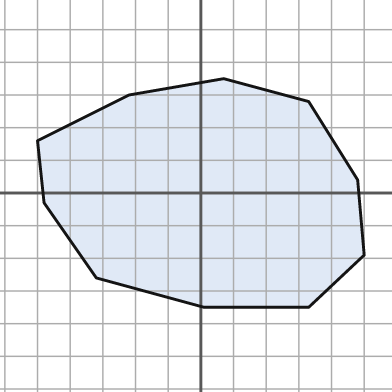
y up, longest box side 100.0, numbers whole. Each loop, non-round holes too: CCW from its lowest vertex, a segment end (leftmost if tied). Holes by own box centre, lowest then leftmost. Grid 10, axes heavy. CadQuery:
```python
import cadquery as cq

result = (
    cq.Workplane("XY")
    .moveTo(1.0, -35.0)
    .lineTo(33.0, -35.0)
    .lineTo(50.0, -19.0)
    .lineTo(48.0, 4.0)
    .lineTo(33.0, 28.0)
    .lineTo(7.0, 35.0)
    .lineTo(-22.0, 30.0)
    .lineTo(-50.0, 16.0)
    .lineTo(-48.0, -3.0)
    .lineTo(-32.0, -26.0)
    .close()
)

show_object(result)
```